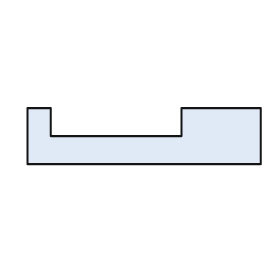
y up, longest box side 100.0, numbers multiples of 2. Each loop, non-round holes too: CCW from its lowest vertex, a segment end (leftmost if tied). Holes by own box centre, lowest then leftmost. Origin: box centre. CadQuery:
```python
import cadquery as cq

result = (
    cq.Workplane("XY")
    .moveTo(-50.0, -12.0)
    .lineTo(50.0, -12.0)
    .lineTo(50.0, 12.0)
    .lineTo(16.0, 12.0)
    .lineTo(16.0, 0.0)
    .lineTo(-40.0, 0.0)
    .lineTo(-40.0, 12.0)
    .lineTo(-50.0, 12.0)
    .close()
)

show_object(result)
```